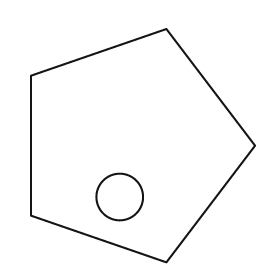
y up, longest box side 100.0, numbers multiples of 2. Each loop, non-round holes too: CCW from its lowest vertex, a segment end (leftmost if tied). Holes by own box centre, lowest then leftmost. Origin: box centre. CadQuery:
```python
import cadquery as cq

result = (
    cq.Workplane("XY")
    .moveTo(10.0, -50.0)
    .lineTo(48.0, 0.0)
    .lineTo(10.0, 50.0)
    .lineTo(-48.0, 30.0)
    .lineTo(-48.0, -30.0)
    .close()
    .moveTo(-10.0, -22.0)
    .circle(10.0)
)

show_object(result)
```